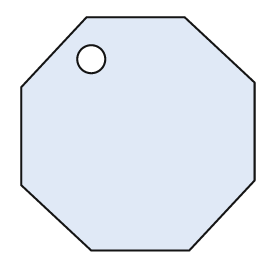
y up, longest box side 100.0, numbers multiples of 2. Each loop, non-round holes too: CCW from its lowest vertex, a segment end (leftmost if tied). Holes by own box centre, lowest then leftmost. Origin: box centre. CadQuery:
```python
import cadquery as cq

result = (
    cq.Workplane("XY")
    .moveTo(-20.0, -50.0)
    .lineTo(22.0, -50.0)
    .lineTo(50.0, -20.0)
    .lineTo(50.0, 22.0)
    .lineTo(20.0, 50.0)
    .lineTo(-22.0, 50.0)
    .lineTo(-50.0, 20.0)
    .lineTo(-50.0, -22.0)
    .close()
    .moveTo(-20.0, 32.0)
    .circle(6.0)
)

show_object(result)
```